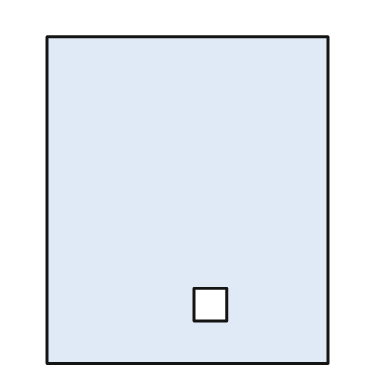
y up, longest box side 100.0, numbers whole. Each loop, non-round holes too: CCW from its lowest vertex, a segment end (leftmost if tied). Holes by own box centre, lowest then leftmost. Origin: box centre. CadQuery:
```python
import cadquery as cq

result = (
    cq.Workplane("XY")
    .moveTo(-43.0, -50.0)
    .lineTo(43.0, -50.0)
    .lineTo(43.0, 50.0)
    .lineTo(-43.0, 50.0)
    .close()
    .moveTo(2.0, -37.0)
    .lineTo(12.0, -37.0)
    .lineTo(12.0, -27.0)
    .lineTo(2.0, -27.0)
    .close()
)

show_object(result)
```